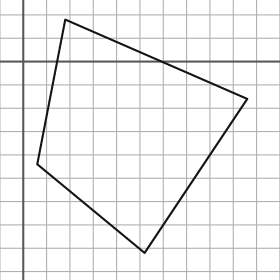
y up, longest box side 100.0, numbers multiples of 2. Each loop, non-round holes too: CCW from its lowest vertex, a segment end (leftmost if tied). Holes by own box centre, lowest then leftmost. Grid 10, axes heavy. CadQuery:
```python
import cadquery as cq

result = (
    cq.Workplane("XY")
    .moveTo(52.0, -82.0)
    .lineTo(96.0, -16.0)
    .lineTo(18.0, 18.0)
    .lineTo(6.0, -44.0)
    .close()
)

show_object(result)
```